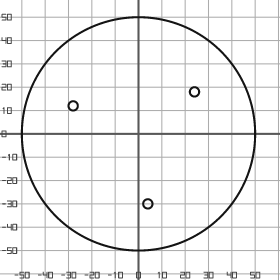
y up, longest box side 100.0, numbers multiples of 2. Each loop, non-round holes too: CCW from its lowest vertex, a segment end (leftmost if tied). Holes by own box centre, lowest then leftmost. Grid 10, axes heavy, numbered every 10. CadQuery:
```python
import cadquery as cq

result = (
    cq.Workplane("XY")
    .moveTo(0.0, 0.0)
    .circle(50.0)
    .moveTo(4.0, -30.0)
    .circle(2.0)
    .moveTo(-28.0, 12.0)
    .circle(2.0)
    .moveTo(24.0, 18.0)
    .circle(2.0)
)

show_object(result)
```